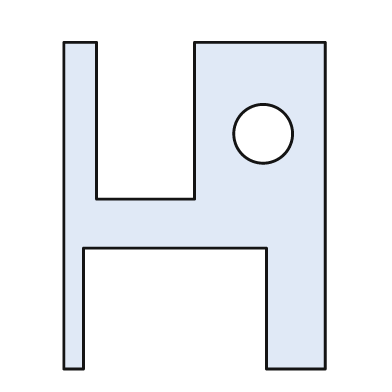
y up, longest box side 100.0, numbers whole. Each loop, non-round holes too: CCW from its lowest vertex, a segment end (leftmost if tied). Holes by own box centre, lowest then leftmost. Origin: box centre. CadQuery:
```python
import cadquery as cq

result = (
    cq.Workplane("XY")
    .moveTo(-40.0, -50.0)
    .lineTo(-34.0, -50.0)
    .lineTo(-34.0, -13.0)
    .lineTo(22.0, -13.0)
    .lineTo(22.0, -50.0)
    .lineTo(40.0, -50.0)
    .lineTo(40.0, 50.0)
    .lineTo(0.0, 50.0)
    .lineTo(0.0, 2.0)
    .lineTo(-30.0, 2.0)
    .lineTo(-30.0, 50.0)
    .lineTo(-40.0, 50.0)
    .close()
    .moveTo(21.0, 22.0)
    .circle(9.0)
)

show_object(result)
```